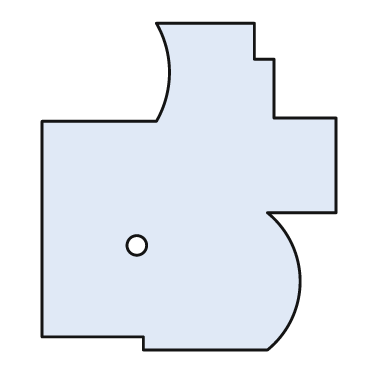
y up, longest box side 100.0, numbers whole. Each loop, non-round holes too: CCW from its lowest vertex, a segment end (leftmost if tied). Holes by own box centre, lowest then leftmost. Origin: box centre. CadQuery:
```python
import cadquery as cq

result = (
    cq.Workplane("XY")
    .moveTo(-14.0, -50.0)
    .lineTo(24.0, -50.0)
    .threePointArc((34.0, -29.0), (24.0, -8.0))
    .lineTo(45.0, -8.0)
    .lineTo(45.0, 21.0)
    .lineTo(26.0, 21.0)
    .lineTo(26.0, 39.0)
    .lineTo(20.0, 39.0)
    .lineTo(20.0, 50.0)
    .lineTo(-10.0, 50.0)
    .threePointArc((-6.0, 35.0), (-10.0, 20.0))
    .lineTo(-45.0, 20.0)
    .lineTo(-45.0, -46.0)
    .lineTo(-14.0, -46.0)
    .close()
    .moveTo(-16.0, -18.0)
    .circle(3.0)
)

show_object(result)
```